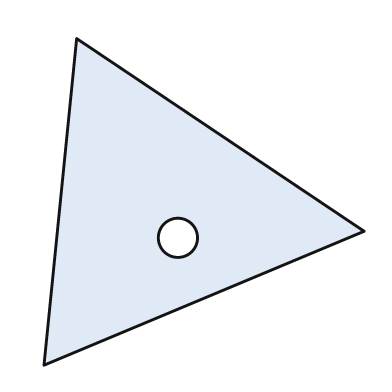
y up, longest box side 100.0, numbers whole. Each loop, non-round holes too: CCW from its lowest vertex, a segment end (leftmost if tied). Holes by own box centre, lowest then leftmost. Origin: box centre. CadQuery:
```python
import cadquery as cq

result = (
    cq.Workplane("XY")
    .moveTo(-49.0, -50.0)
    .lineTo(49.0, -9.0)
    .lineTo(-39.0, 50.0)
    .close()
    .moveTo(-8.0, -11.0)
    .circle(6.0)
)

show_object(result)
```